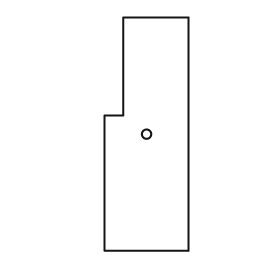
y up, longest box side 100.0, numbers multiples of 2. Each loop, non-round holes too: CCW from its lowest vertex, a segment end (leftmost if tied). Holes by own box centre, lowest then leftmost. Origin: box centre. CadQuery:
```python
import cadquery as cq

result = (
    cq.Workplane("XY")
    .moveTo(-18.0, -50.0)
    .lineTo(18.0, -50.0)
    .lineTo(18.0, 50.0)
    .lineTo(-10.0, 50.0)
    .lineTo(-10.0, 8.0)
    .lineTo(-18.0, 8.0)
    .close()
    .moveTo(0.0, 0.0)
    .circle(2.0)
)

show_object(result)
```